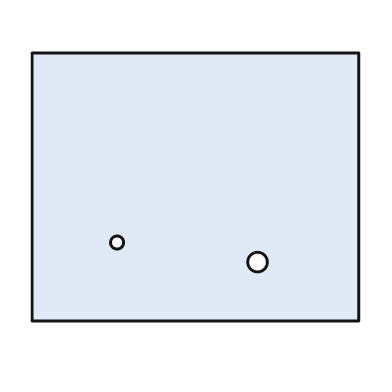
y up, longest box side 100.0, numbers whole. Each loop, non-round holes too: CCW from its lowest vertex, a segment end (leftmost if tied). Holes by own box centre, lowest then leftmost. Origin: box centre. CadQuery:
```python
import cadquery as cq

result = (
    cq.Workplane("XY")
    .moveTo(-50.0, -41.0)
    .lineTo(50.0, -41.0)
    .lineTo(50.0, 41.0)
    .lineTo(-50.0, 41.0)
    .close()
    .moveTo(19.0, -23.0)
    .circle(3.0)
    .moveTo(-24.0, -17.0)
    .circle(2.0)
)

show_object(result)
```